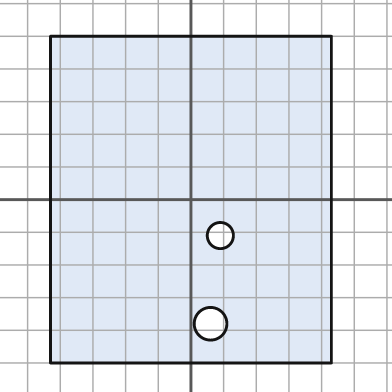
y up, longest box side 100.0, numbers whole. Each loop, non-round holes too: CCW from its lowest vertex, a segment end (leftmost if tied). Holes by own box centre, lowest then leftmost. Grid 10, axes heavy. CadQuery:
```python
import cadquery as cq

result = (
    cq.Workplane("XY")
    .moveTo(-43.0, -50.0)
    .lineTo(43.0, -50.0)
    .lineTo(43.0, 50.0)
    .lineTo(-43.0, 50.0)
    .close()
    .moveTo(6.0, -38.0)
    .circle(5.0)
    .moveTo(9.0, -11.0)
    .circle(4.0)
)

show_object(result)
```